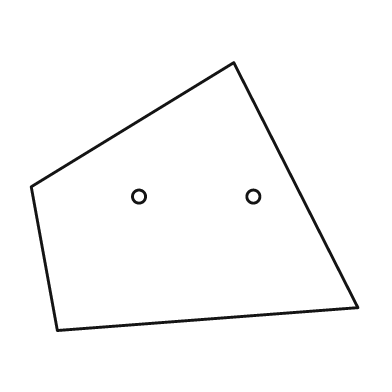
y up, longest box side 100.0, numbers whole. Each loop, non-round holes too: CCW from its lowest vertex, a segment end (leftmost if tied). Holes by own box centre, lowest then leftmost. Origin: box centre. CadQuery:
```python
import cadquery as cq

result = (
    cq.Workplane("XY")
    .moveTo(-42.0, -41.0)
    .lineTo(50.0, -34.0)
    .lineTo(12.0, 41.0)
    .lineTo(-50.0, 3.0)
    .close()
    .moveTo(-17.0, 0.0)
    .circle(2.0)
    .moveTo(18.0, 0.0)
    .circle(2.0)
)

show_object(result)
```